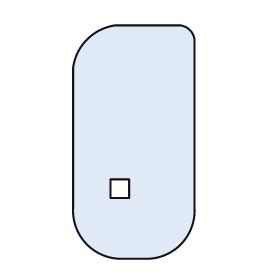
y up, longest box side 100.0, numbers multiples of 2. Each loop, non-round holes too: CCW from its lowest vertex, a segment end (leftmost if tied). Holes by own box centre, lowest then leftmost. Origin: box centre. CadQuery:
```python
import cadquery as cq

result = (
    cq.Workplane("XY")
    .moveTo(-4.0, -50.0)
    .lineTo(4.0, -50.0)
    .threePointArc((20.0, -44.0), (26.0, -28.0))
    .lineTo(26.0, 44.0)
    .threePointArc((24.0, 48.0), (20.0, 50.0))
    .lineTo(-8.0, 50.0)
    .threePointArc((-20.0, 44.0), (-26.0, 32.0))
    .lineTo(-26.0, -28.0)
    .threePointArc((-20.0, -44.0), (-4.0, -50.0))
    .close()
    .moveTo(-10.0, -24.0)
    .lineTo(-2.0, -24.0)
    .lineTo(-2.0, -16.0)
    .lineTo(-10.0, -16.0)
    .close()
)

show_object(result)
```